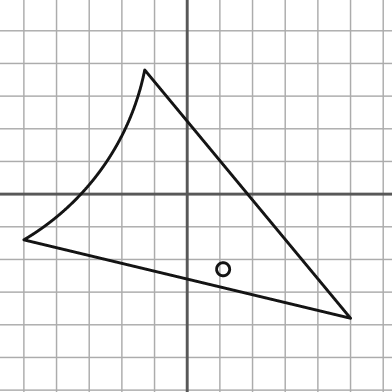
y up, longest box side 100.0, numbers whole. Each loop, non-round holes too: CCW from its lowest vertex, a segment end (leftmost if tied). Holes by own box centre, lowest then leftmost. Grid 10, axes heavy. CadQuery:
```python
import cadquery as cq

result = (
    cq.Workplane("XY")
    .moveTo(50.0, -38.0)
    .lineTo(-13.0, 38.0)
    .threePointArc((-26.0, 8.0), (-50.0, -14.0))
    .close()
    .moveTo(11.0, -23.0)
    .circle(2.0)
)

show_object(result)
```